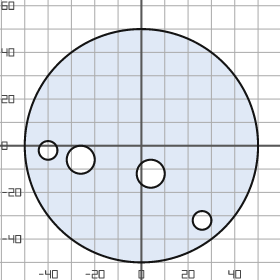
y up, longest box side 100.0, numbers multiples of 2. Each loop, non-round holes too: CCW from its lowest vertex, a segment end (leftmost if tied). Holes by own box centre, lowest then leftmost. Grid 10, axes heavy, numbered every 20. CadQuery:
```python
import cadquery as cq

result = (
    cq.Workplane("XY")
    .moveTo(0.0, 0.0)
    .circle(50.0)
    .moveTo(26.0, -32.0)
    .circle(4.0)
    .moveTo(4.0, -12.0)
    .circle(6.0)
    .moveTo(-26.0, -6.0)
    .circle(6.0)
    .moveTo(-40.0, -2.0)
    .circle(4.0)
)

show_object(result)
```